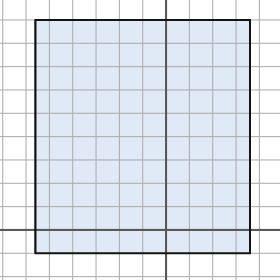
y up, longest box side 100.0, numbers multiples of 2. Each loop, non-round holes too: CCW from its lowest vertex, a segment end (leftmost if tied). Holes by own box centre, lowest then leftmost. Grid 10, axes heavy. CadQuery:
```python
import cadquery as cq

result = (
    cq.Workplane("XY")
    .moveTo(-56.0, -10.0)
    .lineTo(36.0, -10.0)
    .lineTo(36.0, 90.0)
    .lineTo(-56.0, 90.0)
    .close()
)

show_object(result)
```